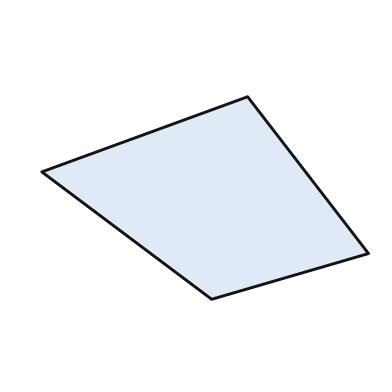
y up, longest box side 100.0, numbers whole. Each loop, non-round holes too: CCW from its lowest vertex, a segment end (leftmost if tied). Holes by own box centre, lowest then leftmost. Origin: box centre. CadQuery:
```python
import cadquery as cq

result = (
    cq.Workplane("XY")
    .moveTo(2.0, -31.0)
    .lineTo(50.0, -17.0)
    .lineTo(13.0, 31.0)
    .lineTo(-50.0, 8.0)
    .close()
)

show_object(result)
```